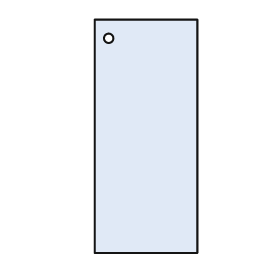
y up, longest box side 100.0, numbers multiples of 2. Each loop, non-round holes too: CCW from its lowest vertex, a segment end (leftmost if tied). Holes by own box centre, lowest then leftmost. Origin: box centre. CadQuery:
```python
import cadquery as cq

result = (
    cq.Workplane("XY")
    .moveTo(-22.0, -50.0)
    .lineTo(22.0, -50.0)
    .lineTo(22.0, 50.0)
    .lineTo(-22.0, 50.0)
    .close()
    .moveTo(-16.0, 42.0)
    .circle(2.0)
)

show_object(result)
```